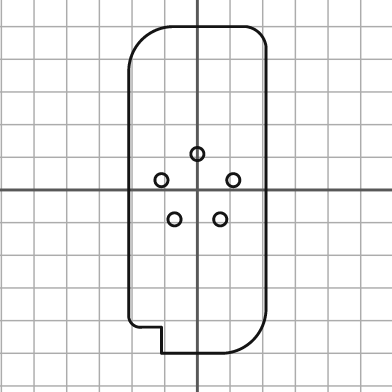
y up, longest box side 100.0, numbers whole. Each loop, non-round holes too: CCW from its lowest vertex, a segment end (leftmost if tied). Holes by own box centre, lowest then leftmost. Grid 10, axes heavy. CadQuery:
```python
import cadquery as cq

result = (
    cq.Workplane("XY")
    .moveTo(-11.0, -50.0)
    .lineTo(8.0, -50.0)
    .threePointArc((17.0, -46.0), (21.0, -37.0))
    .lineTo(21.0, 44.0)
    .threePointArc((19.0, 48.0), (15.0, 50.0))
    .lineTo(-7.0, 50.0)
    .threePointArc((-17.0, 46.0), (-21.0, 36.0))
    .lineTo(-21.0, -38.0)
    .threePointArc((-20.0, -41.0), (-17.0, -42.0))
    .lineTo(-11.0, -42.0)
    .close()
    .moveTo(-7.0, -9.0)
    .circle(2.0)
    .moveTo(7.0, -9.0)
    .circle(2.0)
    .moveTo(-11.0, 3.0)
    .circle(2.0)
    .moveTo(11.0, 3.0)
    .circle(2.0)
    .moveTo(0.0, 11.0)
    .circle(2.0)
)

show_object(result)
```